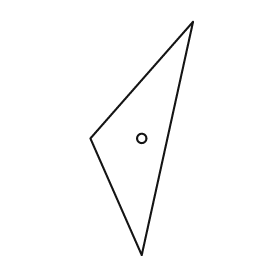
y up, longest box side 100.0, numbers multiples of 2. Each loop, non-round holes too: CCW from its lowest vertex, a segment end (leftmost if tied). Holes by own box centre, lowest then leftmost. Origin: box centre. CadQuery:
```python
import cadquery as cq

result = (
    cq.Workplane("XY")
    .moveTo(0.0, -50.0)
    .lineTo(22.0, 50.0)
    .lineTo(-22.0, 0.0)
    .close()
    .moveTo(0.0, 0.0)
    .circle(2.0)
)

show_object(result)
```